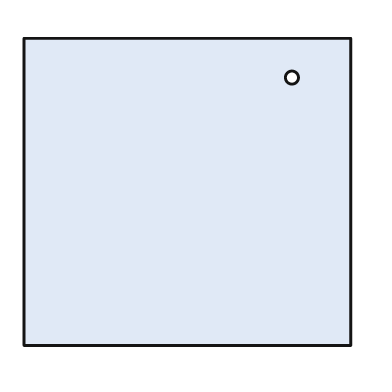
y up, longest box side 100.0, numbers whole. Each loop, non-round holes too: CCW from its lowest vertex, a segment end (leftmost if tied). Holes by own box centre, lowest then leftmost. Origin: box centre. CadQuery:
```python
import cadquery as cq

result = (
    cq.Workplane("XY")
    .moveTo(-50.0, -47.0)
    .lineTo(50.0, -47.0)
    .lineTo(50.0, 47.0)
    .lineTo(-50.0, 47.0)
    .close()
    .moveTo(32.0, 35.0)
    .circle(2.0)
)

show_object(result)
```